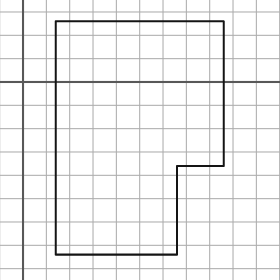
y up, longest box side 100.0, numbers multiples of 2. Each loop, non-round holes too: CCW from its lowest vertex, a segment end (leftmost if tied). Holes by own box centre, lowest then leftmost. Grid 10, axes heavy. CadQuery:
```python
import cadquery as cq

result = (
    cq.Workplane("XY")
    .moveTo(14.0, -74.0)
    .lineTo(66.0, -74.0)
    .lineTo(66.0, -36.0)
    .lineTo(86.0, -36.0)
    .lineTo(86.0, 26.0)
    .lineTo(14.0, 26.0)
    .close()
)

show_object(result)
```